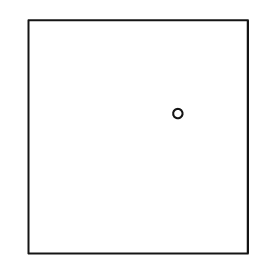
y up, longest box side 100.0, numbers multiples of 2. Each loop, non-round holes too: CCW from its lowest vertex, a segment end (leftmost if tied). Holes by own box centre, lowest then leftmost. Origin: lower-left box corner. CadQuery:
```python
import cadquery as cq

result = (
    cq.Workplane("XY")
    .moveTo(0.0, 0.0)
    .lineTo(94.0, 0.0)
    .lineTo(94.0, 100.0)
    .lineTo(0.0, 100.0)
    .close()
    .moveTo(64.0, 60.0)
    .circle(2.0)
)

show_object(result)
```